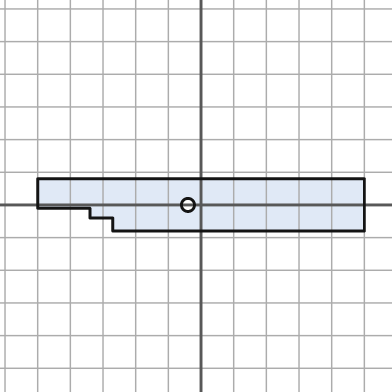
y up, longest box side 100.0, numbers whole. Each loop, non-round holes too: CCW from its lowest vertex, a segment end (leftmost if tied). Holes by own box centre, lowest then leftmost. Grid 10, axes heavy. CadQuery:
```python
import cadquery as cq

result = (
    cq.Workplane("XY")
    .moveTo(-27.0, -8.0)
    .lineTo(50.0, -8.0)
    .lineTo(50.0, 8.0)
    .lineTo(-50.0, 8.0)
    .lineTo(-50.0, -1.0)
    .lineTo(-34.0, -1.0)
    .lineTo(-34.0, -4.0)
    .lineTo(-27.0, -4.0)
    .close()
    .moveTo(-4.0, 0.0)
    .circle(2.0)
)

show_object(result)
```